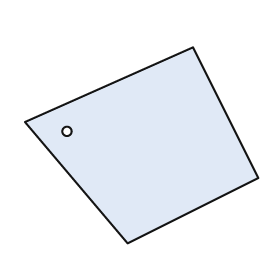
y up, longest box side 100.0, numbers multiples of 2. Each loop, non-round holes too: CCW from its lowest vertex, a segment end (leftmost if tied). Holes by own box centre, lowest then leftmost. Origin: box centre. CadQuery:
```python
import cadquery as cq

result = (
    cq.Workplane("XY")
    .moveTo(-6.0, -42.0)
    .lineTo(50.0, -14.0)
    .lineTo(22.0, 42.0)
    .lineTo(-50.0, 10.0)
    .close()
    .moveTo(-32.0, 6.0)
    .circle(2.0)
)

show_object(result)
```